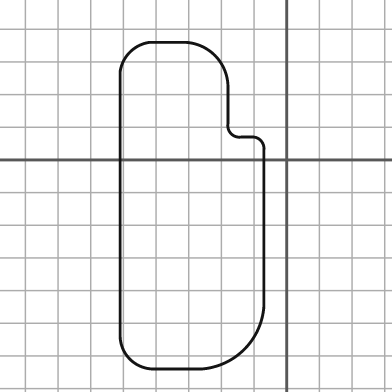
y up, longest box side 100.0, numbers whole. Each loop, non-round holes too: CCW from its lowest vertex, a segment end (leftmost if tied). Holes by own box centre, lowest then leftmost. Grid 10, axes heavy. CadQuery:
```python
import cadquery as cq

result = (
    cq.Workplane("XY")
    .moveTo(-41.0, -64.0)
    .lineTo(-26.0, -64.0)
    .threePointArc((-13.0, -58.0), (-7.0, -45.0))
    .lineTo(-7.0, 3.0)
    .threePointArc((-8.0, 6.0), (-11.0, 7.0))
    .lineTo(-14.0, 7.0)
    .threePointArc((-17.0, 8.0), (-18.0, 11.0))
    .lineTo(-18.0, 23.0)
    .threePointArc((-22.0, 32.0), (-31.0, 36.0))
    .lineTo(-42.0, 36.0)
    .threePointArc((-48.0, 33.0), (-51.0, 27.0))
    .lineTo(-51.0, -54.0)
    .threePointArc((-48.0, -61.0), (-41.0, -64.0))
    .close()
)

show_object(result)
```